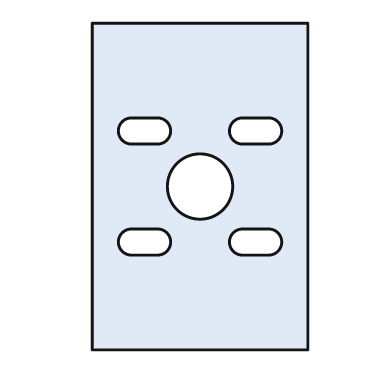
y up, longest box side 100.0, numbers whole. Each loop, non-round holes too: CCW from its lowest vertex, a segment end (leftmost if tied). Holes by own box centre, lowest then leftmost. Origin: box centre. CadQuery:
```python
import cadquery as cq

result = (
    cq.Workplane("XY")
    .moveTo(-33.0, -50.0)
    .lineTo(33.0, -50.0)
    .lineTo(33.0, 50.0)
    .lineTo(-33.0, 50.0)
    .close()
    .moveTo(-21.0, -21.0)
    .lineTo(-13.0, -21.0)
    .threePointArc((-9.0, -17.0), (-13.0, -13.0))
    .lineTo(-21.0, -13.0)
    .threePointArc((-25.0, -17.0), (-21.0, -21.0))
    .close()
    .moveTo(13.0, -21.0)
    .lineTo(21.0, -21.0)
    .threePointArc((25.0, -17.0), (21.0, -13.0))
    .lineTo(13.0, -13.0)
    .threePointArc((9.0, -17.0), (13.0, -21.0))
    .close()
    .moveTo(0.0, 0.0)
    .circle(10.0)
    .moveTo(-21.0, 13.0)
    .lineTo(-13.0, 13.0)
    .threePointArc((-9.0, 17.0), (-13.0, 21.0))
    .lineTo(-21.0, 21.0)
    .threePointArc((-25.0, 17.0), (-21.0, 13.0))
    .close()
    .moveTo(13.0, 13.0)
    .lineTo(21.0, 13.0)
    .threePointArc((25.0, 17.0), (21.0, 21.0))
    .lineTo(13.0, 21.0)
    .threePointArc((9.0, 17.0), (13.0, 13.0))
    .close()
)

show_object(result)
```